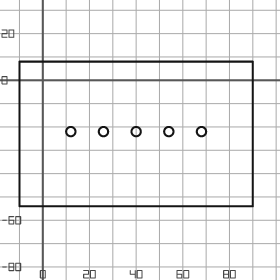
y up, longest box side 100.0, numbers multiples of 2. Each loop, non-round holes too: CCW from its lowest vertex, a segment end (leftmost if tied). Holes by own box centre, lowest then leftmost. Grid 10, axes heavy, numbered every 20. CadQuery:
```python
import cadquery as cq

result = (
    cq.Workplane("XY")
    .moveTo(-10.0, -54.0)
    .lineTo(90.0, -54.0)
    .lineTo(90.0, 8.0)
    .lineTo(-10.0, 8.0)
    .close()
    .moveTo(12.0, -22.0)
    .circle(2.0)
    .moveTo(26.0, -22.0)
    .circle(2.0)
    .moveTo(40.0, -22.0)
    .circle(2.0)
    .moveTo(54.0, -22.0)
    .circle(2.0)
    .moveTo(68.0, -22.0)
    .circle(2.0)
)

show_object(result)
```